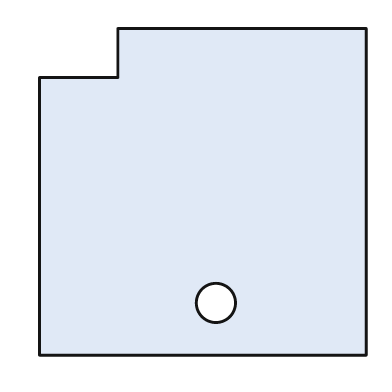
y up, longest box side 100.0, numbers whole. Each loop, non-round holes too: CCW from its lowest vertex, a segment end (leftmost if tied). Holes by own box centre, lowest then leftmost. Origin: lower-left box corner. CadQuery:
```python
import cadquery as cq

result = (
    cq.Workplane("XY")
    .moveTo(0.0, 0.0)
    .lineTo(100.0, 0.0)
    .lineTo(100.0, 100.0)
    .lineTo(24.0, 100.0)
    .lineTo(24.0, 85.0)
    .lineTo(0.0, 85.0)
    .close()
    .moveTo(54.0, 16.0)
    .circle(6.0)
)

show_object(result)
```